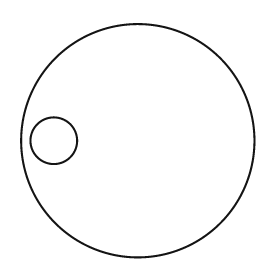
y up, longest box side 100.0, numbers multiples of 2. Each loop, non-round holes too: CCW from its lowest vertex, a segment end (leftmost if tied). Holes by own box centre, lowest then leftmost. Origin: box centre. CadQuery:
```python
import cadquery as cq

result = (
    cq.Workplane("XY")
    .moveTo(0.0, 0.0)
    .circle(50.0)
    .moveTo(-36.0, 0.0)
    .circle(10.0)
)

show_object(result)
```